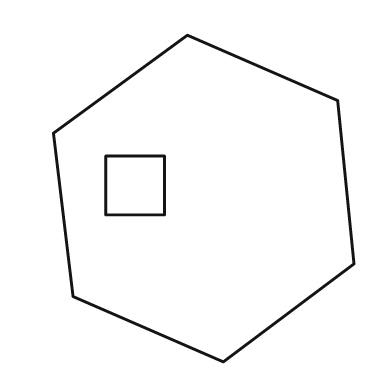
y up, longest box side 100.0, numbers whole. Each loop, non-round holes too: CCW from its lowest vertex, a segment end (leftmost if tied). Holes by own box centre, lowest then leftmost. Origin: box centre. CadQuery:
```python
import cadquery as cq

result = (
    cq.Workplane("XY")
    .moveTo(6.0, -50.0)
    .lineTo(46.0, -20.0)
    .lineTo(41.0, 30.0)
    .lineTo(-5.0, 50.0)
    .lineTo(-46.0, 20.0)
    .lineTo(-40.0, -30.0)
    .close()
    .moveTo(-30.0, -5.0)
    .lineTo(-12.0, -5.0)
    .lineTo(-12.0, 13.0)
    .lineTo(-30.0, 13.0)
    .close()
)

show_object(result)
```